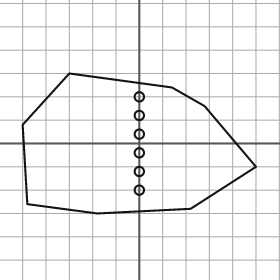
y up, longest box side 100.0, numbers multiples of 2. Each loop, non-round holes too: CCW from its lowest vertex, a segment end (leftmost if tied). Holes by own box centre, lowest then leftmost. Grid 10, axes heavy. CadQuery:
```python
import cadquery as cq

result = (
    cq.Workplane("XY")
    .moveTo(-18.0, -30.0)
    .lineTo(22.0, -28.0)
    .lineTo(50.0, -10.0)
    .lineTo(28.0, 16.0)
    .lineTo(14.0, 24.0)
    .lineTo(-30.0, 30.0)
    .lineTo(-50.0, 8.0)
    .lineTo(-48.0, -26.0)
    .close()
    .moveTo(0.0, -20.0)
    .circle(2.0)
    .moveTo(0.0, -12.0)
    .circle(2.0)
    .moveTo(0.0, -4.0)
    .circle(2.0)
    .moveTo(0.0, 4.0)
    .circle(2.0)
    .moveTo(0.0, 12.0)
    .circle(2.0)
    .moveTo(0.0, 20.0)
    .circle(2.0)
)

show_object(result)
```